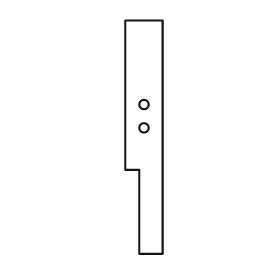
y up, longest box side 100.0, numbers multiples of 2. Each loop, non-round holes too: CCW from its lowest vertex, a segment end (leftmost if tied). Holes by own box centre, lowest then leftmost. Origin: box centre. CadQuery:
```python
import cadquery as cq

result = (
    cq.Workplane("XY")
    .moveTo(-2.0, -50.0)
    .lineTo(8.0, -50.0)
    .lineTo(8.0, 50.0)
    .lineTo(-8.0, 50.0)
    .lineTo(-8.0, -14.0)
    .lineTo(-2.0, -14.0)
    .close()
    .moveTo(0.0, 4.0)
    .circle(2.0)
    .moveTo(0.0, 14.0)
    .circle(2.0)
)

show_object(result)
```